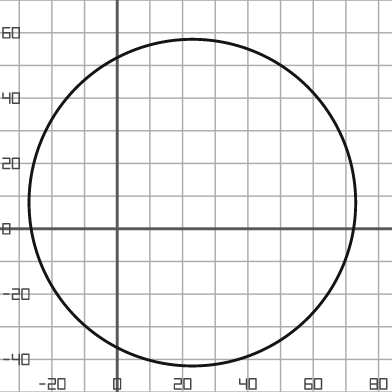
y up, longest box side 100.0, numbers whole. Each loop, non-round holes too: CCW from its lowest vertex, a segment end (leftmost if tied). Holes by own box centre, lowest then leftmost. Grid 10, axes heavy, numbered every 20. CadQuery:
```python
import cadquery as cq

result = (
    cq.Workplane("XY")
    .moveTo(23.0, 8.0)
    .circle(50.0)
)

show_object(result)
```